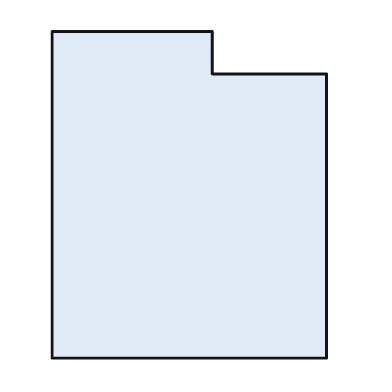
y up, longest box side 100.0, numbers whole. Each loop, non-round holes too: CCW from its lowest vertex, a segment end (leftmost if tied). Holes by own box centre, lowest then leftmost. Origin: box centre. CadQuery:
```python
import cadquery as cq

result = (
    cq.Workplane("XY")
    .moveTo(-42.0, -50.0)
    .lineTo(42.0, -50.0)
    .lineTo(42.0, 37.0)
    .lineTo(7.0, 37.0)
    .lineTo(7.0, 50.0)
    .lineTo(-42.0, 50.0)
    .close()
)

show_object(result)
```